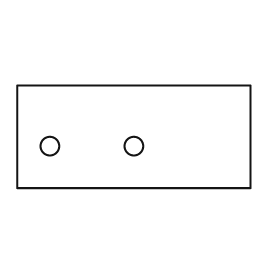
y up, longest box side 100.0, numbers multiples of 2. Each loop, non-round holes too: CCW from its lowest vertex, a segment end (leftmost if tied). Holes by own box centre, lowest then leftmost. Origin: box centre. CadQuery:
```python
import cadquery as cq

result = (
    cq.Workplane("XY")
    .moveTo(-50.0, -22.0)
    .lineTo(50.0, -22.0)
    .lineTo(50.0, 22.0)
    .lineTo(-50.0, 22.0)
    .close()
    .moveTo(-36.0, -4.0)
    .circle(4.0)
    .moveTo(0.0, -4.0)
    .circle(4.0)
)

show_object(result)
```